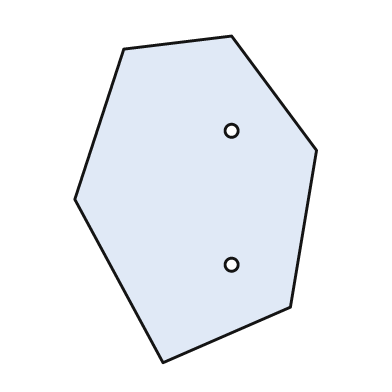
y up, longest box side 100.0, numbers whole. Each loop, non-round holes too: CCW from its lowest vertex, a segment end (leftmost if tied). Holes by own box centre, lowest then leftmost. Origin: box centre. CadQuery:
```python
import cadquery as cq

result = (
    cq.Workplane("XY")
    .moveTo(-10.0, -50.0)
    .lineTo(29.0, -33.0)
    .lineTo(37.0, 15.0)
    .lineTo(11.0, 50.0)
    .lineTo(-22.0, 46.0)
    .lineTo(-37.0, 0.0)
    .close()
    .moveTo(11.0, -20.0)
    .circle(2.0)
    .moveTo(11.0, 21.0)
    .circle(2.0)
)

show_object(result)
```